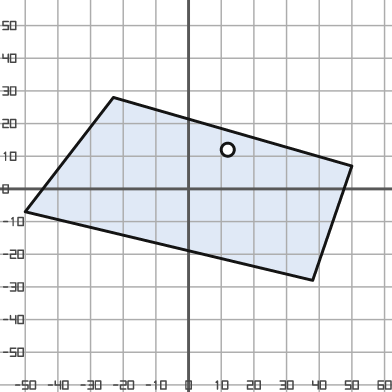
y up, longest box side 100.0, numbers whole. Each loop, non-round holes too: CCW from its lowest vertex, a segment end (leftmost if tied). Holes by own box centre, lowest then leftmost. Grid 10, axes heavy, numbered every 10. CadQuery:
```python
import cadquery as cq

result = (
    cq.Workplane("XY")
    .moveTo(38.0, -28.0)
    .lineTo(50.0, 7.0)
    .lineTo(-23.0, 28.0)
    .lineTo(-50.0, -7.0)
    .close()
    .moveTo(12.0, 12.0)
    .circle(2.0)
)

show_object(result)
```